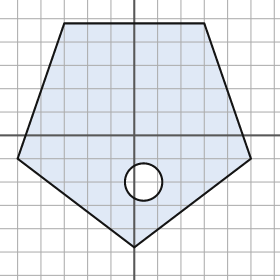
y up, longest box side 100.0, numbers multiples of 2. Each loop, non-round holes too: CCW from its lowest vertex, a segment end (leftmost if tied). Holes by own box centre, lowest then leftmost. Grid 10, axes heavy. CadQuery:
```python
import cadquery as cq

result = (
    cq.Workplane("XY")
    .moveTo(0.0, -48.0)
    .lineTo(50.0, -10.0)
    .lineTo(30.0, 48.0)
    .lineTo(-30.0, 48.0)
    .lineTo(-50.0, -10.0)
    .close()
    .moveTo(4.0, -20.0)
    .circle(8.0)
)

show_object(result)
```